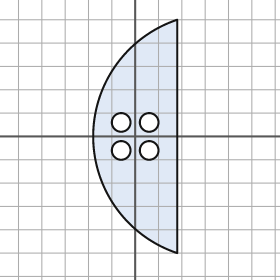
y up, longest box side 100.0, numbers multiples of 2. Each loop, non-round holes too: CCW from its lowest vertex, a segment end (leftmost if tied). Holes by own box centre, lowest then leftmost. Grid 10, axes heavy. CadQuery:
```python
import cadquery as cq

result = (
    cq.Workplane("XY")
    .moveTo(18.0, -50.0)
    .lineTo(18.0, 50.0)
    .threePointArc((-18.0, 0.0), (18.0, -50.0))
    .close()
    .moveTo(-6.0, -6.0)
    .circle(4.0)
    .moveTo(6.0, -6.0)
    .circle(4.0)
    .moveTo(-6.0, 6.0)
    .circle(4.0)
    .moveTo(6.0, 6.0)
    .circle(4.0)
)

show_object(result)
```